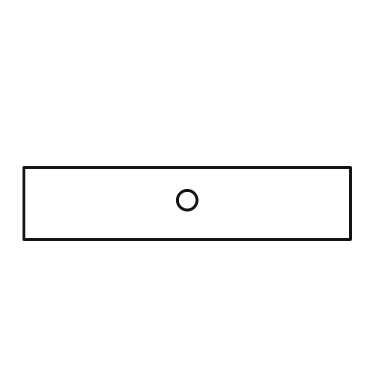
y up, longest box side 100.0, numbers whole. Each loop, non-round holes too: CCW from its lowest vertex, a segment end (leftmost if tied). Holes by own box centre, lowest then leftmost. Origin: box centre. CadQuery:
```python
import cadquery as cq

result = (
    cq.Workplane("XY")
    .moveTo(-50.0, -11.0)
    .lineTo(50.0, -11.0)
    .lineTo(50.0, 11.0)
    .lineTo(-50.0, 11.0)
    .close()
    .moveTo(0.0, 1.0)
    .circle(3.0)
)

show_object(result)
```